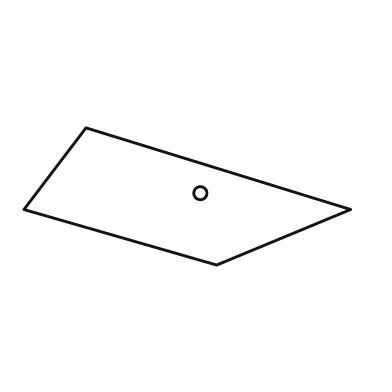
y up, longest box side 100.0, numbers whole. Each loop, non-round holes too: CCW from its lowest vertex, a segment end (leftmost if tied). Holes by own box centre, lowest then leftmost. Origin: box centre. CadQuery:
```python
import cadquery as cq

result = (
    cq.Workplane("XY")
    .moveTo(9.0, -21.0)
    .lineTo(50.0, -4.0)
    .lineTo(-31.0, 21.0)
    .lineTo(-50.0, -4.0)
    .close()
    .moveTo(4.0, 1.0)
    .circle(2.0)
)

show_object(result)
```